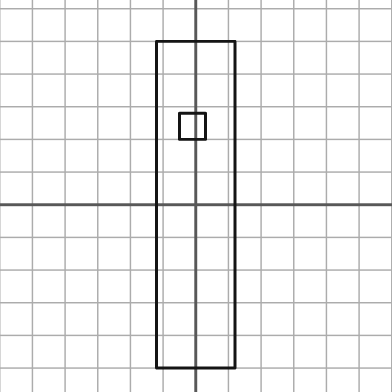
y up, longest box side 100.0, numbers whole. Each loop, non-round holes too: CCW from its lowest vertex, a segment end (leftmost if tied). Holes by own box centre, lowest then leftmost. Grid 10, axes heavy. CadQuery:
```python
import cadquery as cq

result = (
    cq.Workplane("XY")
    .moveTo(-12.0, -50.0)
    .lineTo(12.0, -50.0)
    .lineTo(12.0, 50.0)
    .lineTo(-12.0, 50.0)
    .close()
    .moveTo(-5.0, 20.0)
    .lineTo(3.0, 20.0)
    .lineTo(3.0, 28.0)
    .lineTo(-5.0, 28.0)
    .close()
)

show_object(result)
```